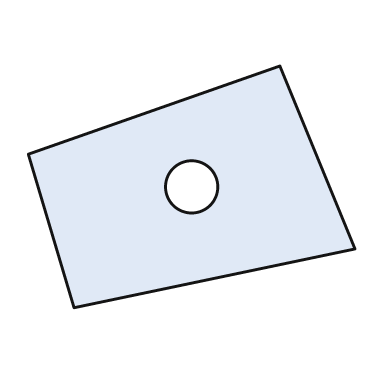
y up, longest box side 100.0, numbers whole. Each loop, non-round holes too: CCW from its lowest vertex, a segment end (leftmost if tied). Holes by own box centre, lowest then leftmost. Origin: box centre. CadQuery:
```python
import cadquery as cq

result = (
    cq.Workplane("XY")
    .moveTo(-36.0, -37.0)
    .lineTo(50.0, -19.0)
    .lineTo(27.0, 37.0)
    .lineTo(-50.0, 10.0)
    .close()
    .moveTo(0.0, 0.0)
    .circle(8.0)
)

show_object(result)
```